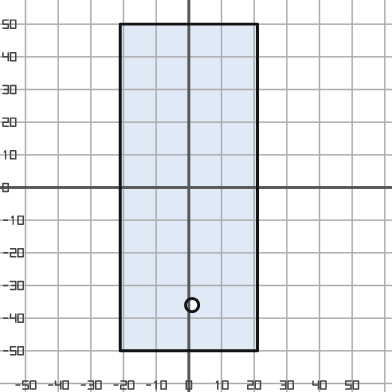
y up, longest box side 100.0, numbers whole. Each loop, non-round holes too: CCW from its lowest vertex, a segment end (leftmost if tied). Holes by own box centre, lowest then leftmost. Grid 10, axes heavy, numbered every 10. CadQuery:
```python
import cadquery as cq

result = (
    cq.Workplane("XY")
    .moveTo(-21.0, -50.0)
    .lineTo(21.0, -50.0)
    .lineTo(21.0, 50.0)
    .lineTo(-21.0, 50.0)
    .close()
    .moveTo(1.0, -36.0)
    .circle(2.0)
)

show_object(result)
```